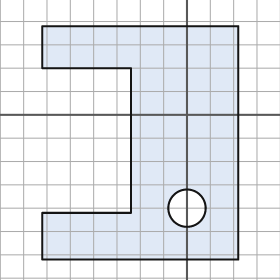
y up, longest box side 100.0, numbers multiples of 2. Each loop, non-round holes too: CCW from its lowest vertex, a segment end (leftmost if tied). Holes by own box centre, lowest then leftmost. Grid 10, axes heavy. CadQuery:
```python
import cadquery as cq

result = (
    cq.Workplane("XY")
    .moveTo(-62.0, -62.0)
    .lineTo(22.0, -62.0)
    .lineTo(22.0, 38.0)
    .lineTo(-62.0, 38.0)
    .lineTo(-62.0, 20.0)
    .lineTo(-24.0, 20.0)
    .lineTo(-24.0, -42.0)
    .lineTo(-62.0, -42.0)
    .close()
    .moveTo(0.0, -40.0)
    .circle(8.0)
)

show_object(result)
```